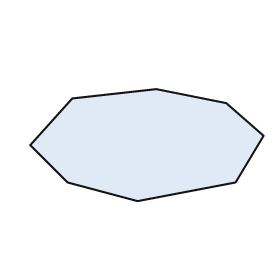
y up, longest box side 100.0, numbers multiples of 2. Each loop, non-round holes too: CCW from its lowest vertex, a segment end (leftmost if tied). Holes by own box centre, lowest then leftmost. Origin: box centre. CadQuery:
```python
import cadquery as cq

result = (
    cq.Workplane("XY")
    .moveTo(-4.0, -24.0)
    .lineTo(38.0, -16.0)
    .lineTo(50.0, 4.0)
    .lineTo(34.0, 18.0)
    .lineTo(4.0, 24.0)
    .lineTo(-32.0, 20.0)
    .lineTo(-50.0, 0.0)
    .lineTo(-34.0, -16.0)
    .close()
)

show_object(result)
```